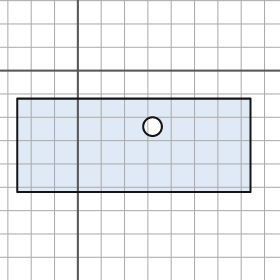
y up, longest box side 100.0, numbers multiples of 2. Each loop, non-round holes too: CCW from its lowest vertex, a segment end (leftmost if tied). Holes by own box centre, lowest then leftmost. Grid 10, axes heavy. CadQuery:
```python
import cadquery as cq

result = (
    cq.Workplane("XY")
    .moveTo(-26.0, -52.0)
    .lineTo(74.0, -52.0)
    .lineTo(74.0, -12.0)
    .lineTo(-26.0, -12.0)
    .close()
    .moveTo(32.0, -24.0)
    .circle(4.0)
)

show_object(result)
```